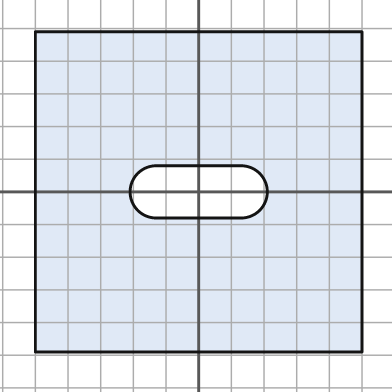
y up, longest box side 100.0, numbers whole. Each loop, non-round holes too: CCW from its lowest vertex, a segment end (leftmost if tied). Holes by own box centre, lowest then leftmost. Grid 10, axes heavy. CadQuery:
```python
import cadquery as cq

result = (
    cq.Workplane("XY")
    .moveTo(-50.0, -49.0)
    .lineTo(50.0, -49.0)
    .lineTo(50.0, 49.0)
    .lineTo(-50.0, 49.0)
    .close()
    .moveTo(-13.0, -8.0)
    .lineTo(13.0, -8.0)
    .threePointArc((21.0, 0.0), (13.0, 8.0))
    .lineTo(-13.0, 8.0)
    .threePointArc((-21.0, 0.0), (-13.0, -8.0))
    .close()
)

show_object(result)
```